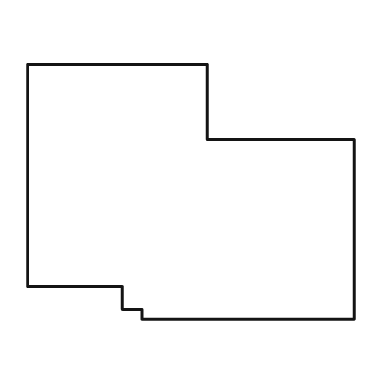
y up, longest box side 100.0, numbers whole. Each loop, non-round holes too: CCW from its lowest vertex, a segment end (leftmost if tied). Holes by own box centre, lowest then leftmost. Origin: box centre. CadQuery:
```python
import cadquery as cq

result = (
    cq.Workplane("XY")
    .moveTo(-15.0, -39.0)
    .lineTo(50.0, -39.0)
    .lineTo(50.0, 16.0)
    .lineTo(5.0, 16.0)
    .lineTo(5.0, 39.0)
    .lineTo(-50.0, 39.0)
    .lineTo(-50.0, -29.0)
    .lineTo(-21.0, -29.0)
    .lineTo(-21.0, -36.0)
    .lineTo(-15.0, -36.0)
    .close()
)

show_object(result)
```